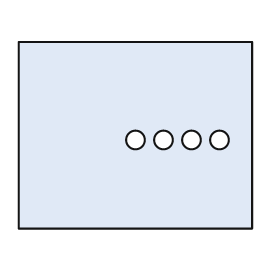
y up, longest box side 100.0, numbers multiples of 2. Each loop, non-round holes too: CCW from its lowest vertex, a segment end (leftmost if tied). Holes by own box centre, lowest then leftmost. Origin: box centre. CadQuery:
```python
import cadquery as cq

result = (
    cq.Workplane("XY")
    .moveTo(-50.0, -40.0)
    .lineTo(50.0, -40.0)
    .lineTo(50.0, 40.0)
    .lineTo(-50.0, 40.0)
    .close()
    .moveTo(0.0, -2.0)
    .circle(4.0)
    .moveTo(12.0, -2.0)
    .circle(4.0)
    .moveTo(24.0, -2.0)
    .circle(4.0)
    .moveTo(36.0, -2.0)
    .circle(4.0)
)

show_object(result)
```